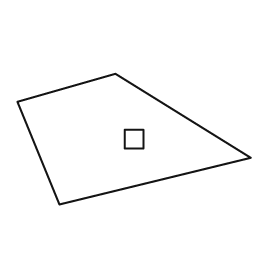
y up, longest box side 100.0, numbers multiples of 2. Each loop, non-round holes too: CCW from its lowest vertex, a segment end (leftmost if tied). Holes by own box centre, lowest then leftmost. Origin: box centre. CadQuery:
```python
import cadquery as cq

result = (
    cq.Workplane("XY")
    .moveTo(-32.0, -28.0)
    .lineTo(50.0, -8.0)
    .lineTo(-8.0, 28.0)
    .lineTo(-50.0, 16.0)
    .close()
    .moveTo(-4.0, -4.0)
    .lineTo(4.0, -4.0)
    .lineTo(4.0, 4.0)
    .lineTo(-4.0, 4.0)
    .close()
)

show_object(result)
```